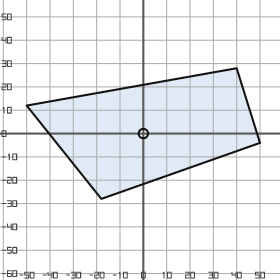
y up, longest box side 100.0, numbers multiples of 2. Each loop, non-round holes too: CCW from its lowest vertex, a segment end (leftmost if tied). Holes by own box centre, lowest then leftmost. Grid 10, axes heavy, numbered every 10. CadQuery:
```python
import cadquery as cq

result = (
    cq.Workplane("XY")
    .moveTo(-18.0, -28.0)
    .lineTo(50.0, -4.0)
    .lineTo(40.0, 28.0)
    .lineTo(-50.0, 12.0)
    .close()
    .moveTo(0.0, 0.0)
    .circle(2.0)
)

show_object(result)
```